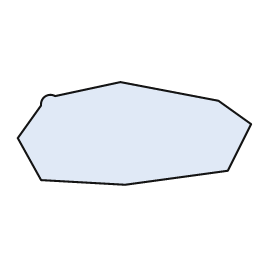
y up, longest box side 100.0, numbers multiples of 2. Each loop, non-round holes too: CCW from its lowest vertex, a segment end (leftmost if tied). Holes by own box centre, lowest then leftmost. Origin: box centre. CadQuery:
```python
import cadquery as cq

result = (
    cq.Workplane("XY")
    .moveTo(-4.0, -22.0)
    .lineTo(40.0, -16.0)
    .lineTo(50.0, 4.0)
    .lineTo(36.0, 14.0)
    .lineTo(-6.0, 22.0)
    .lineTo(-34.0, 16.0)
    .threePointArc((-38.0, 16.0), (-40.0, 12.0))
    .lineTo(-50.0, -2.0)
    .lineTo(-40.0, -20.0)
    .close()
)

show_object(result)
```